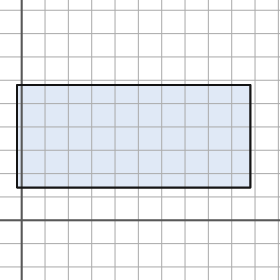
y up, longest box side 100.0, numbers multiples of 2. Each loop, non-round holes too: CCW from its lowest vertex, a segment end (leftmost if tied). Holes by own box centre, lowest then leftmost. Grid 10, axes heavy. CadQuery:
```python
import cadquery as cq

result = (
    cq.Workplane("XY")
    .moveTo(-2.0, 14.0)
    .lineTo(98.0, 14.0)
    .lineTo(98.0, 58.0)
    .lineTo(-2.0, 58.0)
    .close()
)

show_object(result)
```